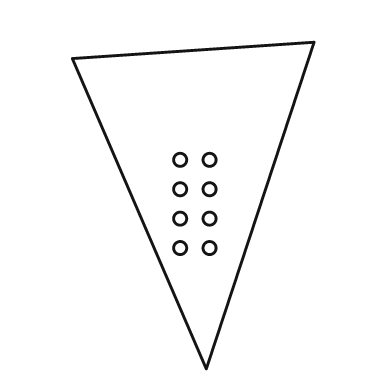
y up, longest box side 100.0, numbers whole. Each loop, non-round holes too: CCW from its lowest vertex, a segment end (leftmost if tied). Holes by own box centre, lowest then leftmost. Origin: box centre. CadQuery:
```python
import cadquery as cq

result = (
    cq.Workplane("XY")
    .moveTo(4.0, -50.0)
    .lineTo(37.0, 50.0)
    .lineTo(-37.0, 45.0)
    .close()
    .moveTo(-4.0, -13.0)
    .circle(2.0)
    .moveTo(5.0, -13.0)
    .circle(2.0)
    .moveTo(-4.0, -4.0)
    .circle(2.0)
    .moveTo(5.0, -4.0)
    .circle(2.0)
    .moveTo(-4.0, 5.0)
    .circle(2.0)
    .moveTo(5.0, 5.0)
    .circle(2.0)
    .moveTo(-4.0, 14.0)
    .circle(2.0)
    .moveTo(5.0, 14.0)
    .circle(2.0)
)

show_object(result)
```